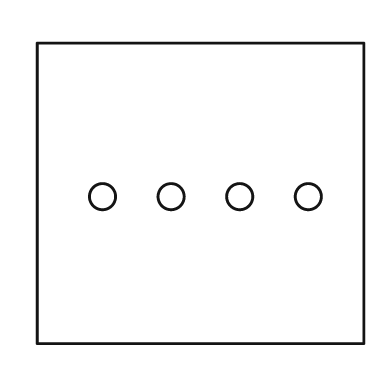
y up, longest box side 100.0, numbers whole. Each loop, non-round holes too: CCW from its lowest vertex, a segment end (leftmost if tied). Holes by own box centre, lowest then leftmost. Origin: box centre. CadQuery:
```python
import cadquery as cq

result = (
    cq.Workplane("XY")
    .moveTo(-50.0, -46.0)
    .lineTo(50.0, -46.0)
    .lineTo(50.0, 46.0)
    .lineTo(-50.0, 46.0)
    .close()
    .moveTo(-30.0, -1.0)
    .circle(4.0)
    .moveTo(-9.0, -1.0)
    .circle(4.0)
    .moveTo(12.0, -1.0)
    .circle(4.0)
    .moveTo(33.0, -1.0)
    .circle(4.0)
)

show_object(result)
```